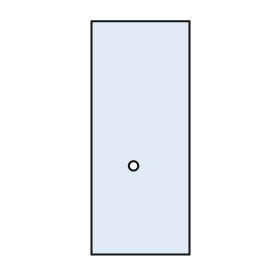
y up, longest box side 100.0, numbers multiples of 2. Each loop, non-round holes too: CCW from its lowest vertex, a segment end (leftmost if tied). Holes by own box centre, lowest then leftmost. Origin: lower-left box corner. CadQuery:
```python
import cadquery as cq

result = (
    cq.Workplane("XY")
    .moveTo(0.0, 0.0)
    .lineTo(42.0, 0.0)
    .lineTo(42.0, 100.0)
    .lineTo(0.0, 100.0)
    .close()
    .moveTo(18.0, 38.0)
    .circle(2.0)
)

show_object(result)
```